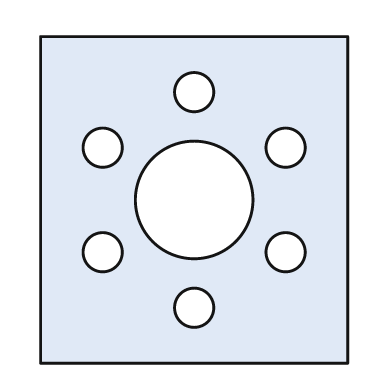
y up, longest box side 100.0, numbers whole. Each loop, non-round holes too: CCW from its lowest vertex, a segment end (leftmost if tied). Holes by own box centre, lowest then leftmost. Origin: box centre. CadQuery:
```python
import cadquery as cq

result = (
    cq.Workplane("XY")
    .moveTo(-47.0, -50.0)
    .lineTo(47.0, -50.0)
    .lineTo(47.0, 50.0)
    .lineTo(-47.0, 50.0)
    .close()
    .moveTo(0.0, -33.0)
    .circle(6.0)
    .moveTo(-28.0, -16.0)
    .circle(6.0)
    .moveTo(28.0, -16.0)
    .circle(6.0)
    .moveTo(0.0, 0.0)
    .circle(18.0)
    .moveTo(-28.0, 16.0)
    .circle(6.0)
    .moveTo(28.0, 16.0)
    .circle(6.0)
    .moveTo(0.0, 33.0)
    .circle(6.0)
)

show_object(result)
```